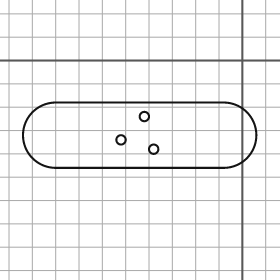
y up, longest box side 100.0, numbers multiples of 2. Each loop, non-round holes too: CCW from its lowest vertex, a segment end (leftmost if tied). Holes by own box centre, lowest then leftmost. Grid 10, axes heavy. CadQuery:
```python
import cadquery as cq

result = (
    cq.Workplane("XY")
    .moveTo(-80.0, -46.0)
    .lineTo(-8.0, -46.0)
    .threePointArc((6.0, -32.0), (-8.0, -18.0))
    .lineTo(-80.0, -18.0)
    .threePointArc((-94.0, -32.0), (-80.0, -46.0))
    .close()
    .moveTo(-38.0, -38.0)
    .circle(2.0)
    .moveTo(-52.0, -34.0)
    .circle(2.0)
    .moveTo(-42.0, -24.0)
    .circle(2.0)
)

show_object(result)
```